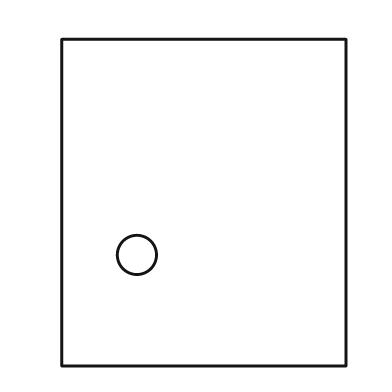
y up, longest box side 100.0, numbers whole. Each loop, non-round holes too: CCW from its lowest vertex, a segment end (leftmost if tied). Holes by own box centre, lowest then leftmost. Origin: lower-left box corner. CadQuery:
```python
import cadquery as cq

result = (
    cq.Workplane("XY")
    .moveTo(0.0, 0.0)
    .lineTo(87.0, 0.0)
    .lineTo(87.0, 100.0)
    .lineTo(0.0, 100.0)
    .close()
    .moveTo(23.0, 34.0)
    .circle(6.0)
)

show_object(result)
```